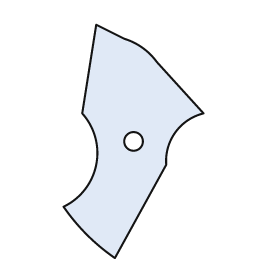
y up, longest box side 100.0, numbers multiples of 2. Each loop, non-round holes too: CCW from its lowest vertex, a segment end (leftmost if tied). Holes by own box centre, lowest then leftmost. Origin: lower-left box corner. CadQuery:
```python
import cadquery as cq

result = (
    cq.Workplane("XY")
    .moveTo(22.0, 0.0)
    .lineTo(44.0, 40.0)
    .threePointArc((48.0, 54.0), (60.0, 62.0))
    .lineTo(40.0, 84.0)
    .threePointArc((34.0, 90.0), (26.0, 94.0))
    .lineTo(14.0, 100.0)
    .lineTo(8.0, 62.0)
    .threePointArc((14.0, 40.0), (0.0, 22.0))
    .threePointArc((10.0, 10.0), (22.0, 0.0))
    .close()
    .moveTo(30.0, 50.0)
    .circle(4.0)
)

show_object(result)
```